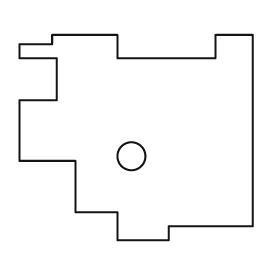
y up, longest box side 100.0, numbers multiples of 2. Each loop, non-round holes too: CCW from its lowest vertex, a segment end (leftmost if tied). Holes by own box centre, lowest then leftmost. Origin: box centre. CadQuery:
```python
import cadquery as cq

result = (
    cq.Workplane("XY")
    .moveTo(-8.0, -44.0)
    .lineTo(14.0, -44.0)
    .lineTo(14.0, -38.0)
    .lineTo(50.0, -38.0)
    .lineTo(50.0, 44.0)
    .lineTo(34.0, 44.0)
    .lineTo(34.0, 34.0)
    .lineTo(-8.0, 34.0)
    .lineTo(-8.0, 44.0)
    .lineTo(-36.0, 44.0)
    .lineTo(-36.0, 40.0)
    .lineTo(-50.0, 40.0)
    .lineTo(-50.0, 34.0)
    .lineTo(-34.0, 34.0)
    .lineTo(-34.0, 16.0)
    .lineTo(-50.0, 16.0)
    .lineTo(-50.0, -10.0)
    .lineTo(-26.0, -10.0)
    .lineTo(-26.0, -32.0)
    .lineTo(-8.0, -32.0)
    .close()
    .moveTo(-2.0, -8.0)
    .circle(6.0)
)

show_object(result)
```